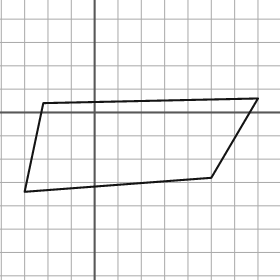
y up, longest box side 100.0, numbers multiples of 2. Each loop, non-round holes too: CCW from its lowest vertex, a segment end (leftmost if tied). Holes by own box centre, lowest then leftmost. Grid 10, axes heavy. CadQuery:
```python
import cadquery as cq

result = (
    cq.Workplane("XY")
    .moveTo(-30.0, -34.0)
    .lineTo(50.0, -28.0)
    .lineTo(70.0, 6.0)
    .lineTo(-22.0, 4.0)
    .close()
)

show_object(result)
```